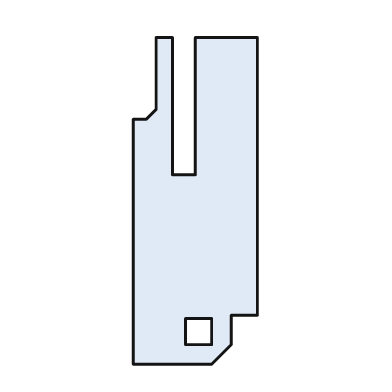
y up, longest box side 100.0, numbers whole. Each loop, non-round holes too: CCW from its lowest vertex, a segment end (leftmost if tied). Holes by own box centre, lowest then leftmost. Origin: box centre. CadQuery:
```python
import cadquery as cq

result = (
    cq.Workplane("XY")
    .moveTo(-19.0, -50.0)
    .lineTo(5.0, -50.0)
    .lineTo(11.0, -44.0)
    .lineTo(11.0, -35.0)
    .lineTo(19.0, -35.0)
    .lineTo(19.0, 50.0)
    .lineTo(0.0, 50.0)
    .lineTo(0.0, 8.0)
    .lineTo(-7.0, 8.0)
    .lineTo(-7.0, 50.0)
    .lineTo(-12.0, 50.0)
    .lineTo(-12.0, 28.0)
    .lineTo(-15.0, 25.0)
    .lineTo(-19.0, 25.0)
    .close()
    .moveTo(-3.0, -44.0)
    .lineTo(5.0, -44.0)
    .lineTo(5.0, -36.0)
    .lineTo(-3.0, -36.0)
    .close()
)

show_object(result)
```